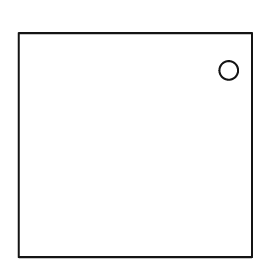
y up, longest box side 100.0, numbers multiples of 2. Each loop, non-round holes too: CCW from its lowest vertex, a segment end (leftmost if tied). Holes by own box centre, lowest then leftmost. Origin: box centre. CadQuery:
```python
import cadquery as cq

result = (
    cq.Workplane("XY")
    .moveTo(-50.0, -48.0)
    .lineTo(50.0, -48.0)
    .lineTo(50.0, 48.0)
    .lineTo(-50.0, 48.0)
    .close()
    .moveTo(40.0, 32.0)
    .circle(4.0)
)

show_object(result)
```